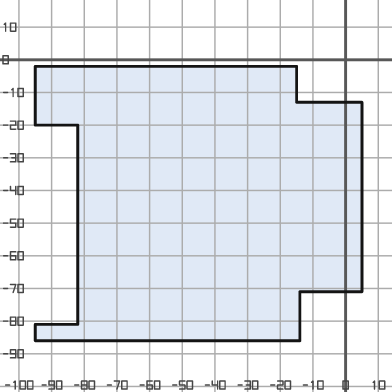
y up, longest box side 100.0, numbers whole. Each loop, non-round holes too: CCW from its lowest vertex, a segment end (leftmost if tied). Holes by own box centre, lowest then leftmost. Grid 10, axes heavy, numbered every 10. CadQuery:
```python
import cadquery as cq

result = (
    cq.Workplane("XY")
    .moveTo(-95.0, -86.0)
    .lineTo(-14.0, -86.0)
    .lineTo(-14.0, -71.0)
    .lineTo(5.0, -71.0)
    .lineTo(5.0, -13.0)
    .lineTo(-15.0, -13.0)
    .lineTo(-15.0, -2.0)
    .lineTo(-95.0, -2.0)
    .lineTo(-95.0, -20.0)
    .lineTo(-82.0, -20.0)
    .lineTo(-82.0, -81.0)
    .lineTo(-95.0, -81.0)
    .close()
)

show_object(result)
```